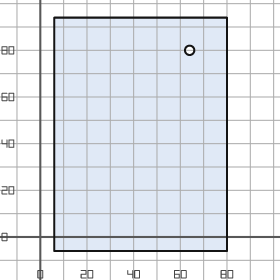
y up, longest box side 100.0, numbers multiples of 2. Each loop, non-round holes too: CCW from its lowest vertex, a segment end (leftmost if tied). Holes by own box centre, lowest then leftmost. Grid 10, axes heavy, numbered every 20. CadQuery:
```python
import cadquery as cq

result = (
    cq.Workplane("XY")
    .moveTo(6.0, -6.0)
    .lineTo(80.0, -6.0)
    .lineTo(80.0, 94.0)
    .lineTo(6.0, 94.0)
    .close()
    .moveTo(64.0, 80.0)
    .circle(2.0)
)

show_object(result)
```